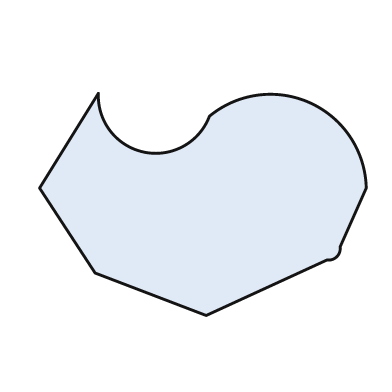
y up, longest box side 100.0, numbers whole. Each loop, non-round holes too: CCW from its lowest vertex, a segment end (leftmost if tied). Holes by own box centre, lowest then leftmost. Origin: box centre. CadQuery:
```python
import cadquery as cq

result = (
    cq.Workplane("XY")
    .moveTo(1.0, -34.0)
    .lineTo(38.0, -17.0)
    .threePointArc((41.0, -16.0), (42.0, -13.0))
    .lineTo(50.0, 5.0)
    .threePointArc((33.0, 31.0), (2.0, 27.0))
    .threePointArc((-18.0, 16.0), (-32.0, 34.0))
    .lineTo(-50.0, 5.0)
    .lineTo(-33.0, -21.0)
    .close()
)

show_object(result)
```